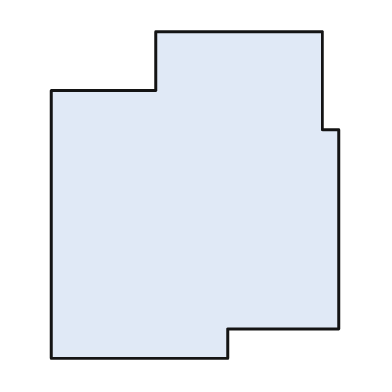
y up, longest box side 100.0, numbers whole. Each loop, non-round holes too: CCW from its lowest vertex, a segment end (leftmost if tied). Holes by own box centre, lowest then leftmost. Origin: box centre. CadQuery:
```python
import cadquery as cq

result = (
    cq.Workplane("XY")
    .moveTo(-44.0, -50.0)
    .lineTo(10.0, -50.0)
    .lineTo(10.0, -41.0)
    .lineTo(44.0, -41.0)
    .lineTo(44.0, 20.0)
    .lineTo(39.0, 20.0)
    .lineTo(39.0, 50.0)
    .lineTo(-12.0, 50.0)
    .lineTo(-12.0, 32.0)
    .lineTo(-44.0, 32.0)
    .close()
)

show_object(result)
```